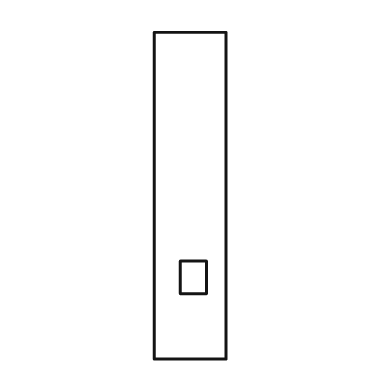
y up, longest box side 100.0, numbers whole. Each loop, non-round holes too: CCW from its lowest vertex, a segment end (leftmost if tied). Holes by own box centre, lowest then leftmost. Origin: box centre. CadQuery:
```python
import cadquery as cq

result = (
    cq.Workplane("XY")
    .moveTo(-11.0, -50.0)
    .lineTo(11.0, -50.0)
    .lineTo(11.0, 50.0)
    .lineTo(-11.0, 50.0)
    .close()
    .moveTo(-3.0, -30.0)
    .lineTo(5.0, -30.0)
    .lineTo(5.0, -20.0)
    .lineTo(-3.0, -20.0)
    .close()
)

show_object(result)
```